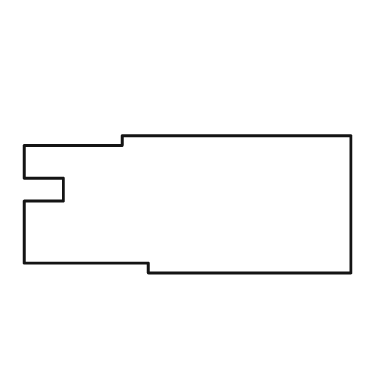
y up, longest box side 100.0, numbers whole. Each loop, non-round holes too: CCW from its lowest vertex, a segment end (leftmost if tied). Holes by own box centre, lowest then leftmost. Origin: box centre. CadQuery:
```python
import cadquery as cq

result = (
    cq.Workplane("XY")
    .moveTo(-12.0, -21.0)
    .lineTo(50.0, -21.0)
    .lineTo(50.0, 21.0)
    .lineTo(-20.0, 21.0)
    .lineTo(-20.0, 18.0)
    .lineTo(-50.0, 18.0)
    .lineTo(-50.0, 8.0)
    .lineTo(-38.0, 8.0)
    .lineTo(-38.0, 1.0)
    .lineTo(-50.0, 1.0)
    .lineTo(-50.0, -18.0)
    .lineTo(-12.0, -18.0)
    .close()
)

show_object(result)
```